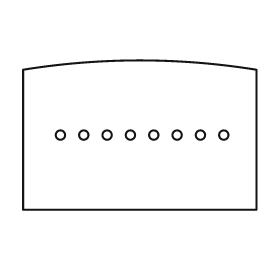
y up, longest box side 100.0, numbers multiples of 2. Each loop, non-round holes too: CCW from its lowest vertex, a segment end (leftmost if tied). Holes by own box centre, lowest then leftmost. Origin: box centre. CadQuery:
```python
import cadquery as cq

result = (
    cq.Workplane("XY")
    .moveTo(-50.0, -32.0)
    .lineTo(50.0, -32.0)
    .lineTo(50.0, 28.0)
    .threePointArc((0.0, 32.0), (-50.0, 28.0))
    .close()
    .moveTo(-34.0, 0.0)
    .circle(2.0)
    .moveTo(-24.0, 0.0)
    .circle(2.0)
    .moveTo(-14.0, 0.0)
    .circle(2.0)
    .moveTo(-4.0, 0.0)
    .circle(2.0)
    .moveTo(6.0, 0.0)
    .circle(2.0)
    .moveTo(16.0, 0.0)
    .circle(2.0)
    .moveTo(26.0, 0.0)
    .circle(2.0)
    .moveTo(36.0, 0.0)
    .circle(2.0)
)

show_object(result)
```